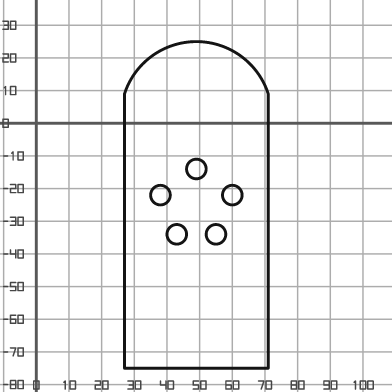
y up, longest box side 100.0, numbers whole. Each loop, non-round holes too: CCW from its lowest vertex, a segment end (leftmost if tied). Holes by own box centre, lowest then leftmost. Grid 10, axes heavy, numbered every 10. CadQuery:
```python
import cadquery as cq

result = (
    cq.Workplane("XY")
    .moveTo(27.0, -75.0)
    .lineTo(71.0, -75.0)
    .lineTo(71.0, 9.0)
    .threePointArc((49.0, 25.0), (27.0, 9.0))
    .close()
    .moveTo(43.0, -34.0)
    .circle(3.0)
    .moveTo(55.0, -34.0)
    .circle(3.0)
    .moveTo(38.0, -22.0)
    .circle(3.0)
    .moveTo(60.0, -22.0)
    .circle(3.0)
    .moveTo(49.0, -14.0)
    .circle(3.0)
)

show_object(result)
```